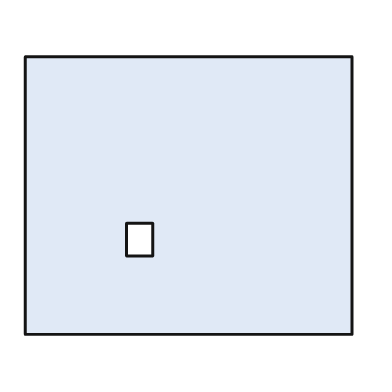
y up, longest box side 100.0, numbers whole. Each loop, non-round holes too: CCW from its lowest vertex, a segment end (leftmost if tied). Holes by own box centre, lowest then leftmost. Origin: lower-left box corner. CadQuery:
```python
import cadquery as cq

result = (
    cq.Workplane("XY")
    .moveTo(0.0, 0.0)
    .lineTo(100.0, 0.0)
    .lineTo(100.0, 85.0)
    .lineTo(0.0, 85.0)
    .close()
    .moveTo(31.0, 24.0)
    .lineTo(39.0, 24.0)
    .lineTo(39.0, 34.0)
    .lineTo(31.0, 34.0)
    .close()
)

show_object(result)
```